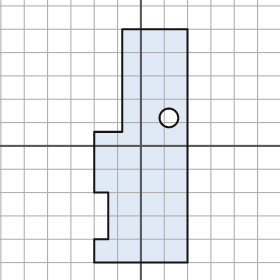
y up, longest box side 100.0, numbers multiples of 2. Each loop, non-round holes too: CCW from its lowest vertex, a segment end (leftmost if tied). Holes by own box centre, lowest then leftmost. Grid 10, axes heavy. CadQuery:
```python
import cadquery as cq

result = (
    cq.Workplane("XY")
    .moveTo(-20.0, -50.0)
    .lineTo(20.0, -50.0)
    .lineTo(20.0, 50.0)
    .lineTo(-8.0, 50.0)
    .lineTo(-8.0, 6.0)
    .lineTo(-20.0, 6.0)
    .lineTo(-20.0, -20.0)
    .lineTo(-14.0, -20.0)
    .lineTo(-14.0, -40.0)
    .lineTo(-20.0, -40.0)
    .close()
    .moveTo(12.0, 12.0)
    .circle(4.0)
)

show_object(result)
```